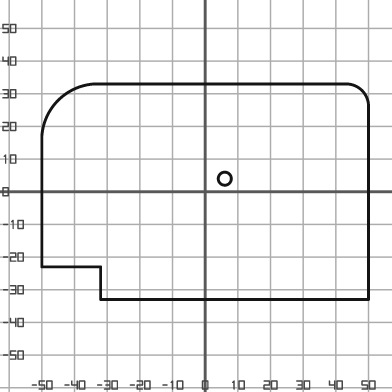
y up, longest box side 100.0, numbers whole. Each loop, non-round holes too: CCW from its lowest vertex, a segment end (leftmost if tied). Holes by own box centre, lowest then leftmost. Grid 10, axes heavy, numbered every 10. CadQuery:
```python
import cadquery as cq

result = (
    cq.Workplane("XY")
    .moveTo(-32.0, -33.0)
    .lineTo(50.0, -33.0)
    .lineTo(50.0, 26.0)
    .threePointArc((48.0, 31.0), (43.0, 33.0))
    .lineTo(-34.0, 33.0)
    .threePointArc((-45.0, 28.0), (-50.0, 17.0))
    .lineTo(-50.0, -23.0)
    .lineTo(-32.0, -23.0)
    .close()
    .moveTo(6.0, 4.0)
    .circle(2.0)
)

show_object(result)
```